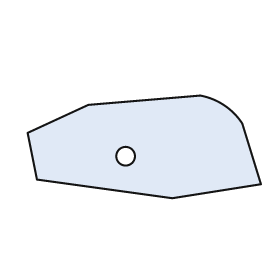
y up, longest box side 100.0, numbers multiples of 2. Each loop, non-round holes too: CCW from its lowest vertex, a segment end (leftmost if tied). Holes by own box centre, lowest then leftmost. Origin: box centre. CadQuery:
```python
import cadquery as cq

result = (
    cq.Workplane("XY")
    .moveTo(12.0, -22.0)
    .lineTo(50.0, -16.0)
    .lineTo(42.0, 10.0)
    .threePointArc((34.0, 18.0), (24.0, 22.0))
    .lineTo(-24.0, 18.0)
    .lineTo(-50.0, 6.0)
    .lineTo(-46.0, -14.0)
    .close()
    .moveTo(-8.0, -4.0)
    .circle(4.0)
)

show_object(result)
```